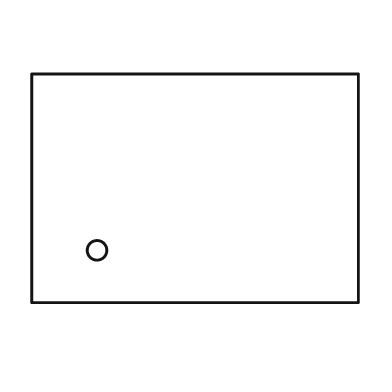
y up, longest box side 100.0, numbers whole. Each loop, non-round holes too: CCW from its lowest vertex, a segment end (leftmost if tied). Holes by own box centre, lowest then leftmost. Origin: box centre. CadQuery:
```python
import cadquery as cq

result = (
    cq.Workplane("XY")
    .moveTo(-50.0, -35.0)
    .lineTo(50.0, -35.0)
    .lineTo(50.0, 35.0)
    .lineTo(-50.0, 35.0)
    .close()
    .moveTo(-30.0, -19.0)
    .circle(3.0)
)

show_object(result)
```